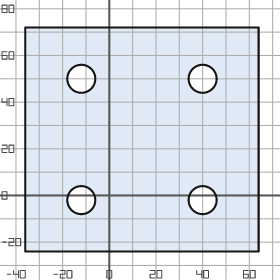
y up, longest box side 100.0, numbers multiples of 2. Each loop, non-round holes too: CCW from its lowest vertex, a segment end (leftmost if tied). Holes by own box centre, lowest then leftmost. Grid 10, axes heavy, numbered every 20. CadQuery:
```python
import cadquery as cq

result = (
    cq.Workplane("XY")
    .moveTo(-36.0, -24.0)
    .lineTo(64.0, -24.0)
    .lineTo(64.0, 72.0)
    .lineTo(-36.0, 72.0)
    .close()
    .moveTo(-12.0, -2.0)
    .circle(6.0)
    .moveTo(40.0, -2.0)
    .circle(6.0)
    .moveTo(-12.0, 50.0)
    .circle(6.0)
    .moveTo(40.0, 50.0)
    .circle(6.0)
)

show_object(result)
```